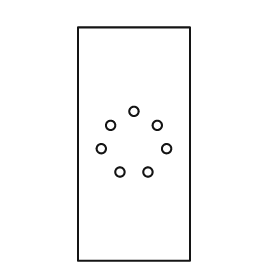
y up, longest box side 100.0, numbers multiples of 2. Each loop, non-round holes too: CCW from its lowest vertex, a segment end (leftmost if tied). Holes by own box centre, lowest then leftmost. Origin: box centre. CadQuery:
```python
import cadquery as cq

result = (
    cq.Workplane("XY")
    .moveTo(-24.0, -50.0)
    .lineTo(24.0, -50.0)
    .lineTo(24.0, 50.0)
    .lineTo(-24.0, 50.0)
    .close()
    .moveTo(-6.0, -12.0)
    .circle(2.0)
    .moveTo(6.0, -12.0)
    .circle(2.0)
    .moveTo(-14.0, -2.0)
    .circle(2.0)
    .moveTo(14.0, -2.0)
    .circle(2.0)
    .moveTo(-10.0, 8.0)
    .circle(2.0)
    .moveTo(10.0, 8.0)
    .circle(2.0)
    .moveTo(0.0, 14.0)
    .circle(2.0)
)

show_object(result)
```